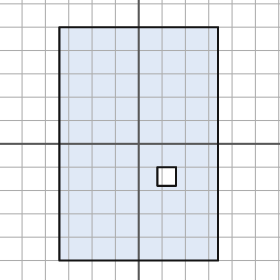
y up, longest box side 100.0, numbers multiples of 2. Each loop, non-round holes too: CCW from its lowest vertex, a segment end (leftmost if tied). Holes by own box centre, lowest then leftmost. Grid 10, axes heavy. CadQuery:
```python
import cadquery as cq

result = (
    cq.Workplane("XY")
    .moveTo(-34.0, -50.0)
    .lineTo(34.0, -50.0)
    .lineTo(34.0, 50.0)
    .lineTo(-34.0, 50.0)
    .close()
    .moveTo(8.0, -18.0)
    .lineTo(16.0, -18.0)
    .lineTo(16.0, -10.0)
    .lineTo(8.0, -10.0)
    .close()
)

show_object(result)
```